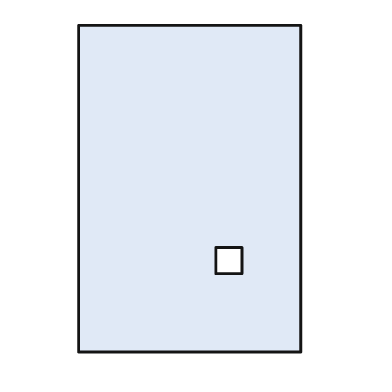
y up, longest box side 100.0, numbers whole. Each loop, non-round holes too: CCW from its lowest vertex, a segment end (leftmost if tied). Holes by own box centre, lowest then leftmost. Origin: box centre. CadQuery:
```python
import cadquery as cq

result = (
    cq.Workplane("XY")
    .moveTo(-34.0, -50.0)
    .lineTo(34.0, -50.0)
    .lineTo(34.0, 50.0)
    .lineTo(-34.0, 50.0)
    .close()
    .moveTo(8.0, -26.0)
    .lineTo(16.0, -26.0)
    .lineTo(16.0, -18.0)
    .lineTo(8.0, -18.0)
    .close()
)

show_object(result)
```